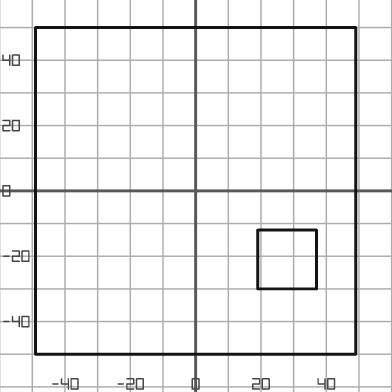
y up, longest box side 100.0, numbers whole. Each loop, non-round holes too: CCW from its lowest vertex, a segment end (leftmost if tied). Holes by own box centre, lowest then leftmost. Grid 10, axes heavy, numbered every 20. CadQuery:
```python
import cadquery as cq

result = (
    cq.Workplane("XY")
    .moveTo(-49.0, -50.0)
    .lineTo(49.0, -50.0)
    .lineTo(49.0, 50.0)
    .lineTo(-49.0, 50.0)
    .close()
    .moveTo(19.0, -30.0)
    .lineTo(37.0, -30.0)
    .lineTo(37.0, -12.0)
    .lineTo(19.0, -12.0)
    .close()
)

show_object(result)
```